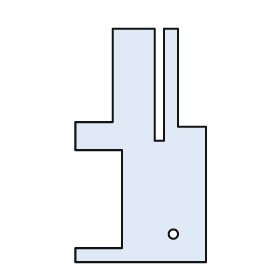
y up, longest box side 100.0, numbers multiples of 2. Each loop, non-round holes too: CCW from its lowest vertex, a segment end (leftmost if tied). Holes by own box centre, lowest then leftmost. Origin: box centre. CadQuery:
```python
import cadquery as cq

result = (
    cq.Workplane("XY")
    .moveTo(-28.0, -50.0)
    .lineTo(28.0, -50.0)
    .lineTo(28.0, 8.0)
    .lineTo(16.0, 8.0)
    .lineTo(16.0, 50.0)
    .lineTo(10.0, 50.0)
    .lineTo(10.0, 2.0)
    .lineTo(6.0, 2.0)
    .lineTo(6.0, 50.0)
    .lineTo(-12.0, 50.0)
    .lineTo(-12.0, 10.0)
    .lineTo(-28.0, 10.0)
    .lineTo(-28.0, -2.0)
    .lineTo(-8.0, -2.0)
    .lineTo(-8.0, -44.0)
    .lineTo(-28.0, -44.0)
    .close()
    .moveTo(14.0, -38.0)
    .circle(2.0)
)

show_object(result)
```